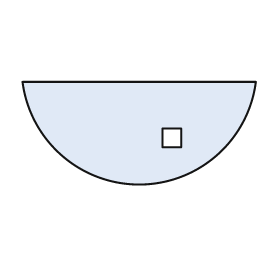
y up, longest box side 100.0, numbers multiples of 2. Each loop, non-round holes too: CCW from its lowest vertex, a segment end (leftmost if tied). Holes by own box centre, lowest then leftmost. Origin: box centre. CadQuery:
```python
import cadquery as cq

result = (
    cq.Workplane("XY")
    .moveTo(-50.0, 22.0)
    .threePointArc((0.0, -22.0), (50.0, 22.0))
    .close()
    .moveTo(10.0, -6.0)
    .lineTo(18.0, -6.0)
    .lineTo(18.0, 2.0)
    .lineTo(10.0, 2.0)
    .close()
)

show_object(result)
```